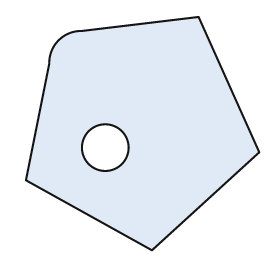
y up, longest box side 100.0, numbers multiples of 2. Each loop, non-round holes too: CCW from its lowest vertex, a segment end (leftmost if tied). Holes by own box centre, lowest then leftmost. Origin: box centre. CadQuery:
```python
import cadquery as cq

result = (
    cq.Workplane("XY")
    .moveTo(4.0, -50.0)
    .lineTo(50.0, -8.0)
    .lineTo(24.0, 50.0)
    .lineTo(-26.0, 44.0)
    .threePointArc((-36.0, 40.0), (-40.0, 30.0))
    .lineTo(-50.0, -20.0)
    .close()
    .moveTo(-16.0, -6.0)
    .circle(10.0)
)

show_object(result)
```